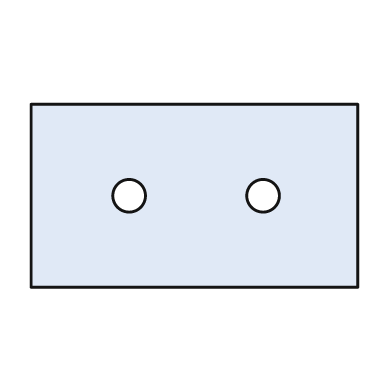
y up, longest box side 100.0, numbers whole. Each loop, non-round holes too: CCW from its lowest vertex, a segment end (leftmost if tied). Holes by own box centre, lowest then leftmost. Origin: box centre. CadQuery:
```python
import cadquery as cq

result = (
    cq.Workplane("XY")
    .moveTo(-50.0, -28.0)
    .lineTo(50.0, -28.0)
    .lineTo(50.0, 28.0)
    .lineTo(-50.0, 28.0)
    .close()
    .moveTo(-20.0, 0.0)
    .circle(5.0)
    .moveTo(21.0, 0.0)
    .circle(5.0)
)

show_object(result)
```